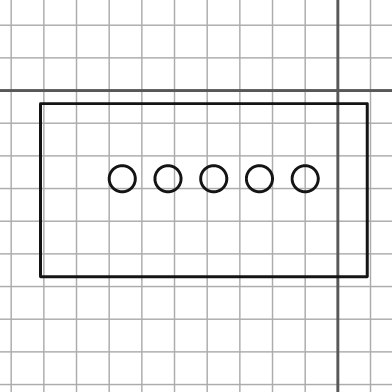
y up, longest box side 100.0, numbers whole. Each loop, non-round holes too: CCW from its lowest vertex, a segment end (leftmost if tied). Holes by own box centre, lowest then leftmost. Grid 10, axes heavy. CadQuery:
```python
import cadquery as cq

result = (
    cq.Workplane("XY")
    .moveTo(-91.0, -57.0)
    .lineTo(9.0, -57.0)
    .lineTo(9.0, -4.0)
    .lineTo(-91.0, -4.0)
    .close()
    .moveTo(-66.0, -27.0)
    .circle(4.0)
    .moveTo(-52.0, -27.0)
    .circle(4.0)
    .moveTo(-38.0, -27.0)
    .circle(4.0)
    .moveTo(-24.0, -27.0)
    .circle(4.0)
    .moveTo(-10.0, -27.0)
    .circle(4.0)
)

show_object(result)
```